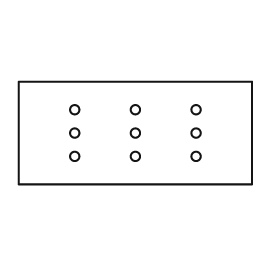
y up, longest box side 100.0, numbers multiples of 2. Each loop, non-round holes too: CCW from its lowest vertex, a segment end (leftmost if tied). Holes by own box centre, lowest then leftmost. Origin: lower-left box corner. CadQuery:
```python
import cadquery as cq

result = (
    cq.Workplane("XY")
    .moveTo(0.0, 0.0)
    .lineTo(100.0, 0.0)
    .lineTo(100.0, 44.0)
    .lineTo(0.0, 44.0)
    .close()
    .moveTo(24.0, 12.0)
    .circle(2.0)
    .moveTo(50.0, 12.0)
    .circle(2.0)
    .moveTo(76.0, 12.0)
    .circle(2.0)
    .moveTo(24.0, 22.0)
    .circle(2.0)
    .moveTo(50.0, 22.0)
    .circle(2.0)
    .moveTo(76.0, 22.0)
    .circle(2.0)
    .moveTo(24.0, 32.0)
    .circle(2.0)
    .moveTo(50.0, 32.0)
    .circle(2.0)
    .moveTo(76.0, 32.0)
    .circle(2.0)
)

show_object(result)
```